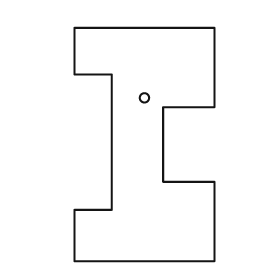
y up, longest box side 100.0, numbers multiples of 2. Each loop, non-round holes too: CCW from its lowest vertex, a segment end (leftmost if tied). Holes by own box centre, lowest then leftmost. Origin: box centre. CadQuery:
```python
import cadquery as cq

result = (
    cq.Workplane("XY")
    .moveTo(-30.0, -50.0)
    .lineTo(30.0, -50.0)
    .lineTo(30.0, -16.0)
    .lineTo(8.0, -16.0)
    .lineTo(8.0, 16.0)
    .lineTo(30.0, 16.0)
    .lineTo(30.0, 50.0)
    .lineTo(-30.0, 50.0)
    .lineTo(-30.0, 30.0)
    .lineTo(-14.0, 30.0)
    .lineTo(-14.0, -28.0)
    .lineTo(-30.0, -28.0)
    .close()
    .moveTo(0.0, 20.0)
    .circle(2.0)
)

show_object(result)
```